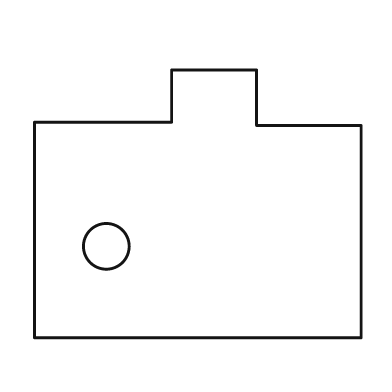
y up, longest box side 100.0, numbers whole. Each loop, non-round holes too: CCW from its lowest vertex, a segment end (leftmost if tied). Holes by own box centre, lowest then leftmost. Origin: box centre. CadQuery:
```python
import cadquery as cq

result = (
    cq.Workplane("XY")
    .moveTo(-50.0, -41.0)
    .lineTo(50.0, -41.0)
    .lineTo(50.0, 24.0)
    .lineTo(18.0, 24.0)
    .lineTo(18.0, 41.0)
    .lineTo(-8.0, 41.0)
    .lineTo(-8.0, 25.0)
    .lineTo(-50.0, 25.0)
    .close()
    .moveTo(-28.0, -13.0)
    .circle(7.0)
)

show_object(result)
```